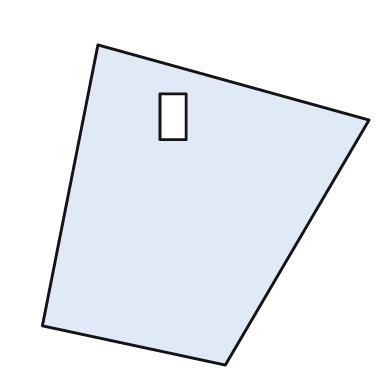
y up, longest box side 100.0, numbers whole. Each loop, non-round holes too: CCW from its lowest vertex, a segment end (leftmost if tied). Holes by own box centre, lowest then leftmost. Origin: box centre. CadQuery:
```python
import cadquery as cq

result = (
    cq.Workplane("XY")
    .moveTo(6.0, -49.0)
    .lineTo(50.0, 26.0)
    .lineTo(-33.0, 49.0)
    .lineTo(-50.0, -37.0)
    .close()
    .moveTo(-14.0, 20.0)
    .lineTo(-6.0, 20.0)
    .lineTo(-6.0, 34.0)
    .lineTo(-14.0, 34.0)
    .close()
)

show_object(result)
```